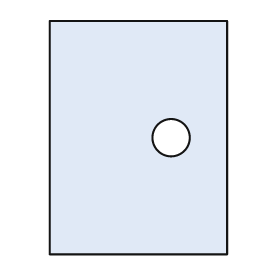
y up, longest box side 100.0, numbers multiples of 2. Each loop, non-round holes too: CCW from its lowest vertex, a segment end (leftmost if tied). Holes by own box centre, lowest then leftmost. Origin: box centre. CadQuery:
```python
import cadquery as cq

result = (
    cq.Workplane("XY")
    .moveTo(-38.0, -50.0)
    .lineTo(38.0, -50.0)
    .lineTo(38.0, 50.0)
    .lineTo(-38.0, 50.0)
    .close()
    .moveTo(14.0, 0.0)
    .circle(8.0)
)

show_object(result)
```